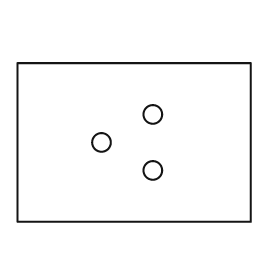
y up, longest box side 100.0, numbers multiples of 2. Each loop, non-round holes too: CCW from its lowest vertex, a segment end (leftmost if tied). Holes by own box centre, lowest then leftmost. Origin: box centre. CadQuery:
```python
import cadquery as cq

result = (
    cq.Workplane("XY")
    .moveTo(-50.0, -34.0)
    .lineTo(50.0, -34.0)
    .lineTo(50.0, 34.0)
    .lineTo(-50.0, 34.0)
    .close()
    .moveTo(8.0, -12.0)
    .circle(4.0)
    .moveTo(-14.0, 0.0)
    .circle(4.0)
    .moveTo(8.0, 12.0)
    .circle(4.0)
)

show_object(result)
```